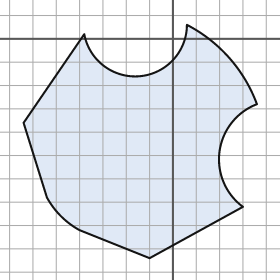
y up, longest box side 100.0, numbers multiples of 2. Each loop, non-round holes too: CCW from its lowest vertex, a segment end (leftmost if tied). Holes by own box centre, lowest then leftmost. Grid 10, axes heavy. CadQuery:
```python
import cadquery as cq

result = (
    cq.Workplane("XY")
    .moveTo(-10.0, -94.0)
    .lineTo(30.0, -72.0)
    .threePointArc((20.0, -48.0), (36.0, -28.0))
    .threePointArc((24.0, -8.0), (6.0, 6.0))
    .threePointArc((-14.0, -16.0), (-38.0, 2.0))
    .lineTo(-64.0, -36.0)
    .lineTo(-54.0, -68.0)
    .threePointArc((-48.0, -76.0), (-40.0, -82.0))
    .close()
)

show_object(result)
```